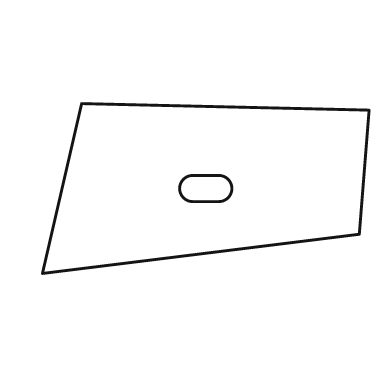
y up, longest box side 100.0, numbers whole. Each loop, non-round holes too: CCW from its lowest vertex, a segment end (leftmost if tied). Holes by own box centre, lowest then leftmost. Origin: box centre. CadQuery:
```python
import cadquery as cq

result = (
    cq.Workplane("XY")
    .moveTo(-50.0, -26.0)
    .lineTo(47.0, -14.0)
    .lineTo(50.0, 24.0)
    .lineTo(-38.0, 26.0)
    .close()
    .moveTo(-4.0, -4.0)
    .lineTo(4.0, -4.0)
    .threePointArc((8.0, 0.0), (4.0, 4.0))
    .lineTo(-4.0, 4.0)
    .threePointArc((-8.0, 0.0), (-4.0, -4.0))
    .close()
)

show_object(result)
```